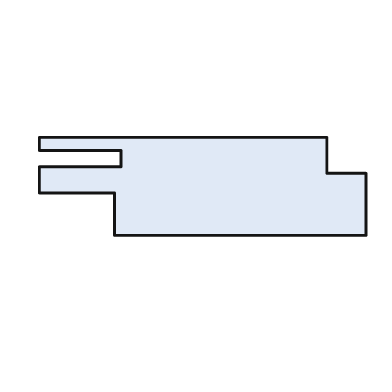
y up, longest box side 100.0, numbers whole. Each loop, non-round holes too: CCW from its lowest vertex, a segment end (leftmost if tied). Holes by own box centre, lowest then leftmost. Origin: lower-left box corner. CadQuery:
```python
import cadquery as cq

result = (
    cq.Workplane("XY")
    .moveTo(23.0, 0.0)
    .lineTo(100.0, 0.0)
    .lineTo(100.0, 19.0)
    .lineTo(88.0, 19.0)
    .lineTo(88.0, 30.0)
    .lineTo(0.0, 30.0)
    .lineTo(0.0, 26.0)
    .lineTo(25.0, 26.0)
    .lineTo(25.0, 21.0)
    .lineTo(0.0, 21.0)
    .lineTo(0.0, 13.0)
    .lineTo(23.0, 13.0)
    .close()
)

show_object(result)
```